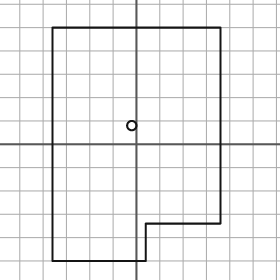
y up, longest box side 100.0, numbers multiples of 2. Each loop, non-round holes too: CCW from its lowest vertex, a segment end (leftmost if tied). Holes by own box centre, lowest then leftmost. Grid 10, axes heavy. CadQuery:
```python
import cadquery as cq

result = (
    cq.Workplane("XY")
    .moveTo(-36.0, -50.0)
    .lineTo(4.0, -50.0)
    .lineTo(4.0, -34.0)
    .lineTo(36.0, -34.0)
    .lineTo(36.0, 50.0)
    .lineTo(-36.0, 50.0)
    .close()
    .moveTo(-2.0, 8.0)
    .circle(2.0)
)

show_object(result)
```